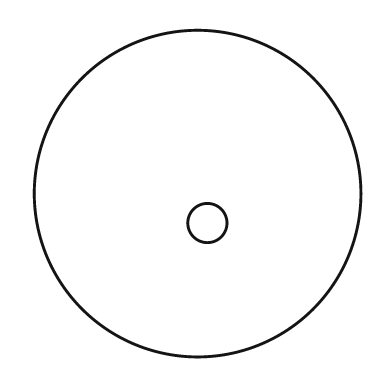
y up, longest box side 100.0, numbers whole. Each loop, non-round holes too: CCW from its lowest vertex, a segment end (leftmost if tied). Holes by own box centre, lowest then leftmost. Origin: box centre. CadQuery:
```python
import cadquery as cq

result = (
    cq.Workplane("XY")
    .moveTo(0.0, 0.0)
    .circle(50.0)
    .moveTo(3.0, -9.0)
    .circle(6.0)
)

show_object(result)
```